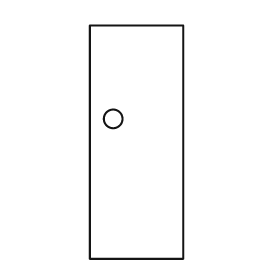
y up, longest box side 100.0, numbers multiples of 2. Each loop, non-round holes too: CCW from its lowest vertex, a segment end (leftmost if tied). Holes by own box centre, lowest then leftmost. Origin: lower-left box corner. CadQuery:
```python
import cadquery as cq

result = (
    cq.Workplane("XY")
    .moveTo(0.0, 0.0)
    .lineTo(40.0, 0.0)
    .lineTo(40.0, 100.0)
    .lineTo(0.0, 100.0)
    .close()
    .moveTo(10.0, 60.0)
    .circle(4.0)
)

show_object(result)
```